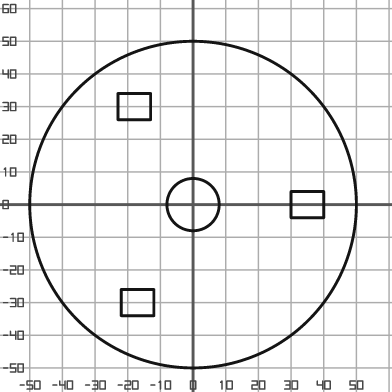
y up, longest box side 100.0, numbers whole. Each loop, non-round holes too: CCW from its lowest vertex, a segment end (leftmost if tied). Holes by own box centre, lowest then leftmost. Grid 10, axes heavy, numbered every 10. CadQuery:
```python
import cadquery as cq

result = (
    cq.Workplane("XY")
    .moveTo(0.0, 0.0)
    .circle(50.0)
    .moveTo(-22.0, -34.0)
    .lineTo(-12.0, -34.0)
    .lineTo(-12.0, -26.0)
    .lineTo(-22.0, -26.0)
    .close()
    .moveTo(0.0, 0.0)
    .circle(8.0)
    .moveTo(30.0, -4.0)
    .lineTo(40.0, -4.0)
    .lineTo(40.0, 4.0)
    .lineTo(30.0, 4.0)
    .close()
    .moveTo(-23.0, 26.0)
    .lineTo(-13.0, 26.0)
    .lineTo(-13.0, 34.0)
    .lineTo(-23.0, 34.0)
    .close()
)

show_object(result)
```